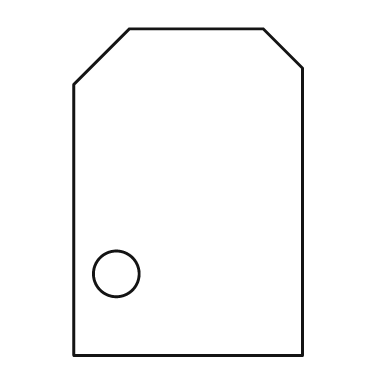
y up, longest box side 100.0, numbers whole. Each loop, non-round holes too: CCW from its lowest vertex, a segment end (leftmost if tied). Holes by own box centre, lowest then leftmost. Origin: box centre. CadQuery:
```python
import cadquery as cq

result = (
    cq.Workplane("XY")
    .moveTo(-35.0, -50.0)
    .lineTo(35.0, -50.0)
    .lineTo(35.0, 38.0)
    .lineTo(23.0, 50.0)
    .lineTo(-18.0, 50.0)
    .lineTo(-35.0, 33.0)
    .close()
    .moveTo(-22.0, -25.0)
    .circle(7.0)
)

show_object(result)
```